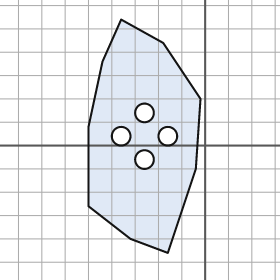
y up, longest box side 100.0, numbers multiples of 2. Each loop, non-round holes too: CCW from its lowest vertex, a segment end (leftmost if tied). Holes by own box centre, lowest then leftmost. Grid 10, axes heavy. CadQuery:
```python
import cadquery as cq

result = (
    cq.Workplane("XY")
    .moveTo(-16.0, -46.0)
    .lineTo(-4.0, -10.0)
    .lineTo(-2.0, 20.0)
    .lineTo(-18.0, 44.0)
    .lineTo(-36.0, 54.0)
    .lineTo(-44.0, 36.0)
    .lineTo(-50.0, 8.0)
    .lineTo(-50.0, -26.0)
    .lineTo(-32.0, -40.0)
    .close()
    .moveTo(-26.0, -6.0)
    .circle(4.0)
    .moveTo(-36.0, 4.0)
    .circle(4.0)
    .moveTo(-16.0, 4.0)
    .circle(4.0)
    .moveTo(-26.0, 14.0)
    .circle(4.0)
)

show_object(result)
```